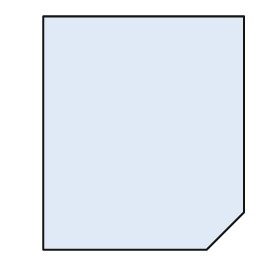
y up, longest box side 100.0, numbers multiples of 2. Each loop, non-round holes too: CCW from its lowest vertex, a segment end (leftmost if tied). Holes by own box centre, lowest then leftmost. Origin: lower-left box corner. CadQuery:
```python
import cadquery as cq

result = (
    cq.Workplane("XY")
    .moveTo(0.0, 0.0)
    .lineTo(70.0, 0.0)
    .lineTo(86.0, 16.0)
    .lineTo(86.0, 100.0)
    .lineTo(0.0, 100.0)
    .close()
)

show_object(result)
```